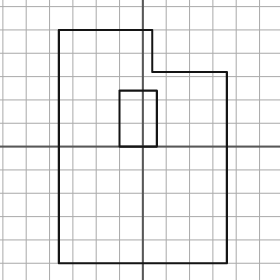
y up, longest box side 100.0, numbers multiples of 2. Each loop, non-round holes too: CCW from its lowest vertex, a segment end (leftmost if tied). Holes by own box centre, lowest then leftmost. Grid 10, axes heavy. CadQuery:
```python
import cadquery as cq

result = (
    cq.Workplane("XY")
    .moveTo(-36.0, -50.0)
    .lineTo(36.0, -50.0)
    .lineTo(36.0, 32.0)
    .lineTo(4.0, 32.0)
    .lineTo(4.0, 50.0)
    .lineTo(-36.0, 50.0)
    .close()
    .moveTo(-10.0, 0.0)
    .lineTo(6.0, 0.0)
    .lineTo(6.0, 24.0)
    .lineTo(-10.0, 24.0)
    .close()
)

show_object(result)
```